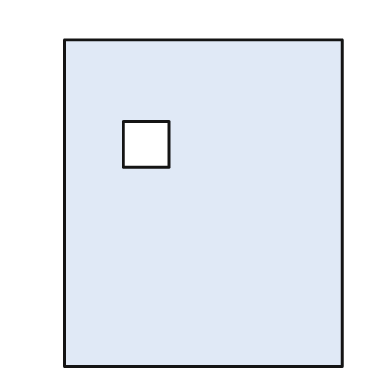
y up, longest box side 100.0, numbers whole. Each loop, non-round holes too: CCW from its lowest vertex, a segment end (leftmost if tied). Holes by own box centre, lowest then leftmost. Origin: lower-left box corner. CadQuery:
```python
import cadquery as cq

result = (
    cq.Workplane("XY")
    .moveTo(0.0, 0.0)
    .lineTo(85.0, 0.0)
    .lineTo(85.0, 100.0)
    .lineTo(0.0, 100.0)
    .close()
    .moveTo(18.0, 61.0)
    .lineTo(32.0, 61.0)
    .lineTo(32.0, 75.0)
    .lineTo(18.0, 75.0)
    .close()
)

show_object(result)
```